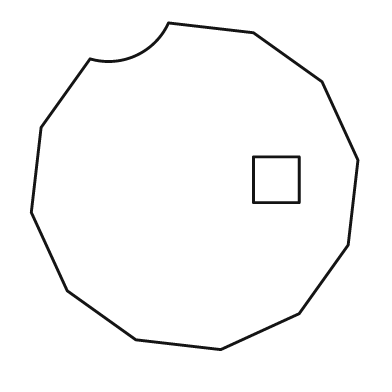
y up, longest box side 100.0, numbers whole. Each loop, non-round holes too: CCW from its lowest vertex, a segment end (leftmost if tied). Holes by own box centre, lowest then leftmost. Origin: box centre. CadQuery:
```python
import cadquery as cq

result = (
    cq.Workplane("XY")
    .moveTo(8.0, -50.0)
    .lineTo(32.0, -39.0)
    .lineTo(47.0, -18.0)
    .lineTo(50.0, 8.0)
    .lineTo(39.0, 32.0)
    .lineTo(18.0, 47.0)
    .lineTo(-8.0, 50.0)
    .threePointArc((-18.0, 40.0), (-32.0, 39.0))
    .lineTo(-47.0, 18.0)
    .lineTo(-50.0, -8.0)
    .lineTo(-39.0, -32.0)
    .lineTo(-18.0, -47.0)
    .close()
    .moveTo(18.0, -5.0)
    .lineTo(32.0, -5.0)
    .lineTo(32.0, 9.0)
    .lineTo(18.0, 9.0)
    .close()
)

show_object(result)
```